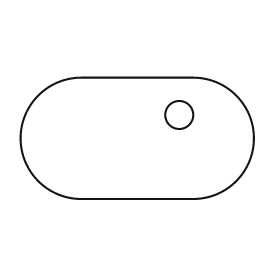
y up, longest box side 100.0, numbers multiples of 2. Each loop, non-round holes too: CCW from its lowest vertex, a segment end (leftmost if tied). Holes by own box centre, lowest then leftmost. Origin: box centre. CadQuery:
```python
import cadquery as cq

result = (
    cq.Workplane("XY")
    .moveTo(-24.0, -26.0)
    .lineTo(24.0, -26.0)
    .threePointArc((50.0, 0.0), (24.0, 26.0))
    .lineTo(-24.0, 26.0)
    .threePointArc((-50.0, 0.0), (-24.0, -26.0))
    .close()
    .moveTo(18.0, 10.0)
    .circle(6.0)
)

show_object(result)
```